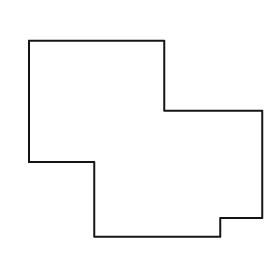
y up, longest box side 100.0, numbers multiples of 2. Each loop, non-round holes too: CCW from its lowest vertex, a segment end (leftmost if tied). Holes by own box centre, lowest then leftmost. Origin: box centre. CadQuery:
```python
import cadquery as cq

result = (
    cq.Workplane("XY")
    .moveTo(-22.0, -42.0)
    .lineTo(32.0, -42.0)
    .lineTo(32.0, -34.0)
    .lineTo(50.0, -34.0)
    .lineTo(50.0, 12.0)
    .lineTo(8.0, 12.0)
    .lineTo(8.0, 42.0)
    .lineTo(-50.0, 42.0)
    .lineTo(-50.0, -10.0)
    .lineTo(-22.0, -10.0)
    .close()
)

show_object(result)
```